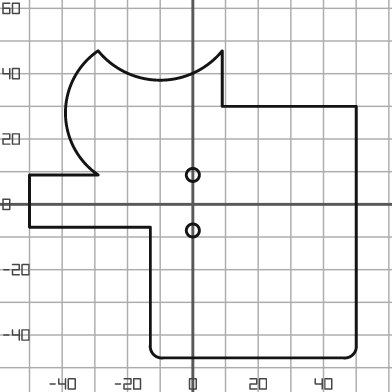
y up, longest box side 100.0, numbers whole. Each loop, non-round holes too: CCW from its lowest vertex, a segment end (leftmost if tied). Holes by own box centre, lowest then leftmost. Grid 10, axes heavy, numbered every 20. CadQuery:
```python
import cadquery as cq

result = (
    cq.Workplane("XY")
    .moveTo(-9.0, -47.0)
    .lineTo(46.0, -47.0)
    .threePointArc((49.0, -46.0), (50.0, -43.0))
    .lineTo(50.0, 30.0)
    .lineTo(9.0, 30.0)
    .lineTo(9.0, 47.0)
    .threePointArc((-10.0, 38.0), (-29.0, 47.0))
    .threePointArc((-39.0, 28.0), (-29.0, 9.0))
    .lineTo(-50.0, 9.0)
    .lineTo(-50.0, -7.0)
    .lineTo(-13.0, -7.0)
    .lineTo(-13.0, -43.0)
    .threePointArc((-12.0, -46.0), (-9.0, -47.0))
    .close()
    .moveTo(0.0, -8.0)
    .circle(2.0)
    .moveTo(0.0, 9.0)
    .circle(2.0)
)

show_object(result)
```